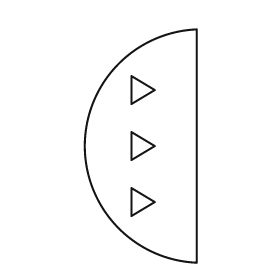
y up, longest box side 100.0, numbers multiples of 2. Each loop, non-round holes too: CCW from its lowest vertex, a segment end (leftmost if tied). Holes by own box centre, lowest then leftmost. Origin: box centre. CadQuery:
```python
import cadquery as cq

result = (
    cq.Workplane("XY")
    .moveTo(24.0, -50.0)
    .lineTo(24.0, 50.0)
    .threePointArc((-24.0, 0.0), (24.0, -50.0))
    .close()
    .moveTo(-4.0, -30.0)
    .lineTo(6.0, -24.0)
    .lineTo(-4.0, -18.0)
    .close()
    .moveTo(-4.0, -6.0)
    .lineTo(6.0, 0.0)
    .lineTo(-4.0, 6.0)
    .close()
    .moveTo(-4.0, 18.0)
    .lineTo(6.0, 24.0)
    .lineTo(-4.0, 30.0)
    .close()
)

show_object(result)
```